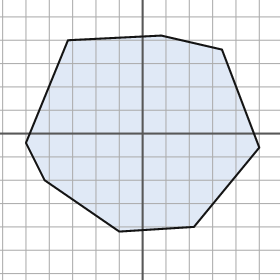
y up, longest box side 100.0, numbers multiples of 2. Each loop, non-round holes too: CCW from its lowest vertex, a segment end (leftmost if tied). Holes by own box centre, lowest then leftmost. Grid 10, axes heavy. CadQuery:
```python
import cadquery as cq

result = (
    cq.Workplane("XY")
    .moveTo(-10.0, -42.0)
    .lineTo(22.0, -40.0)
    .lineTo(50.0, -6.0)
    .lineTo(34.0, 36.0)
    .lineTo(8.0, 42.0)
    .lineTo(-32.0, 40.0)
    .lineTo(-50.0, -4.0)
    .lineTo(-42.0, -20.0)
    .close()
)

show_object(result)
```